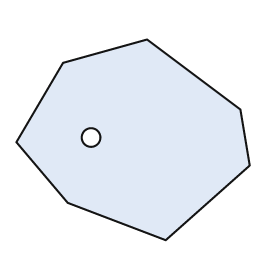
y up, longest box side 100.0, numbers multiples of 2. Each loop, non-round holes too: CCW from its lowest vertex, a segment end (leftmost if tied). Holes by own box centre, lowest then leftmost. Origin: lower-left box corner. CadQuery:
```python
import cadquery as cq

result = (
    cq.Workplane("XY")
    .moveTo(64.0, 0.0)
    .lineTo(100.0, 32.0)
    .lineTo(96.0, 56.0)
    .lineTo(56.0, 86.0)
    .lineTo(20.0, 76.0)
    .lineTo(0.0, 42.0)
    .lineTo(22.0, 16.0)
    .close()
    .moveTo(32.0, 44.0)
    .circle(4.0)
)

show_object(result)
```